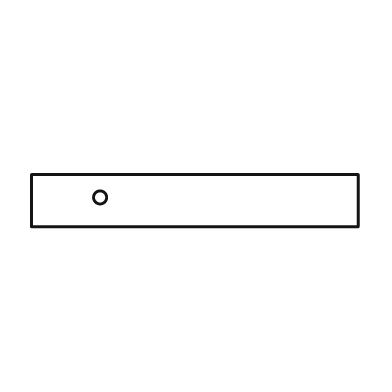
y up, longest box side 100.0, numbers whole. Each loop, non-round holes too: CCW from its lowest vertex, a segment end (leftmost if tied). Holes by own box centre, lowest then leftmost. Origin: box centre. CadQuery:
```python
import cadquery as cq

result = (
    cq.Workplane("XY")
    .moveTo(-50.0, -8.0)
    .lineTo(50.0, -8.0)
    .lineTo(50.0, 8.0)
    .lineTo(-50.0, 8.0)
    .close()
    .moveTo(-29.0, 1.0)
    .circle(2.0)
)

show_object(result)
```